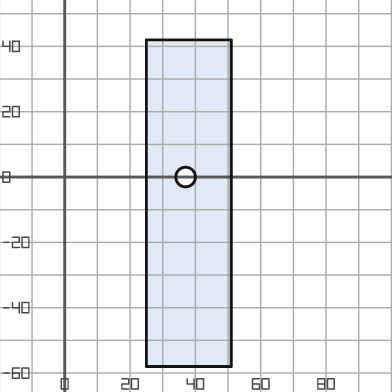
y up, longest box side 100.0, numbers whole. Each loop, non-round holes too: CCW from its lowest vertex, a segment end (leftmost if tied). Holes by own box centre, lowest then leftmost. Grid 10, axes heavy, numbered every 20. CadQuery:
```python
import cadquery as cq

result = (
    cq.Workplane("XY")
    .moveTo(25.0, -58.0)
    .lineTo(51.0, -58.0)
    .lineTo(51.0, 42.0)
    .lineTo(25.0, 42.0)
    .close()
    .moveTo(37.0, 0.0)
    .circle(3.0)
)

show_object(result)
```